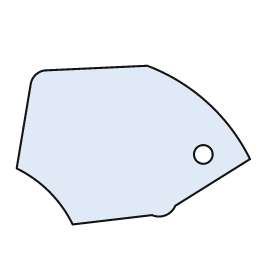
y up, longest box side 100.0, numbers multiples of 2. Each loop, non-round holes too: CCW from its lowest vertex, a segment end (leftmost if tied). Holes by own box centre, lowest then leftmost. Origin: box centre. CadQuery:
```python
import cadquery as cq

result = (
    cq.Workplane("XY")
    .moveTo(-26.0, -34.0)
    .lineTo(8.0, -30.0)
    .threePointArc((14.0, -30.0), (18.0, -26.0))
    .lineTo(50.0, -6.0)
    .threePointArc((32.0, 18.0), (6.0, 34.0))
    .lineTo(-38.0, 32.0)
    .threePointArc((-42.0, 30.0), (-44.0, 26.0))
    .lineTo(-50.0, -10.0)
    .threePointArc((-36.0, -20.0), (-26.0, -34.0))
    .close()
    .moveTo(30.0, -4.0)
    .circle(4.0)
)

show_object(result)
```